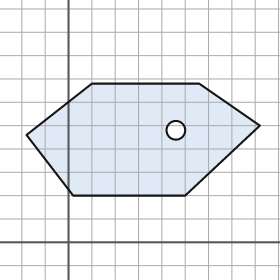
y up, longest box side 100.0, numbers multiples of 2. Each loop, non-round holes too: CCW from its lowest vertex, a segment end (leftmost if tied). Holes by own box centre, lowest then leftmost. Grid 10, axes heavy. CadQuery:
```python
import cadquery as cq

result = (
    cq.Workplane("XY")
    .moveTo(2.0, 20.0)
    .lineTo(50.0, 20.0)
    .lineTo(82.0, 50.0)
    .lineTo(56.0, 68.0)
    .lineTo(10.0, 68.0)
    .lineTo(-18.0, 46.0)
    .close()
    .moveTo(46.0, 48.0)
    .circle(4.0)
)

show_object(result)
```